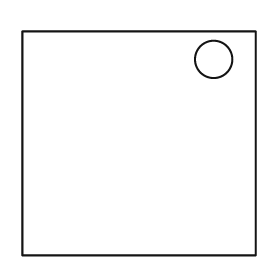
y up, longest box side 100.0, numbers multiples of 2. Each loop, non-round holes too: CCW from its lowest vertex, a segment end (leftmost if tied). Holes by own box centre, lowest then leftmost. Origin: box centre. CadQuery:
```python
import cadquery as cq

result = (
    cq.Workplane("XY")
    .moveTo(-50.0, -48.0)
    .lineTo(50.0, -48.0)
    .lineTo(50.0, 48.0)
    .lineTo(-50.0, 48.0)
    .close()
    .moveTo(32.0, 36.0)
    .circle(8.0)
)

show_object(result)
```